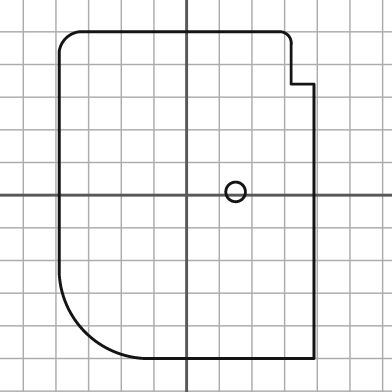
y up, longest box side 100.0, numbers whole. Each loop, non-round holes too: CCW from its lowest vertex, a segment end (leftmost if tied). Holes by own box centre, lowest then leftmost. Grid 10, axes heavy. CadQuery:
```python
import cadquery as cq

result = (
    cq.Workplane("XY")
    .moveTo(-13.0, -50.0)
    .lineTo(39.0, -50.0)
    .lineTo(39.0, 34.0)
    .lineTo(32.0, 34.0)
    .lineTo(32.0, 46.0)
    .threePointArc((31.0, 49.0), (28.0, 50.0))
    .lineTo(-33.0, 50.0)
    .threePointArc((-37.0, 48.0), (-39.0, 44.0))
    .lineTo(-39.0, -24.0)
    .threePointArc((-31.0, -42.0), (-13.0, -50.0))
    .close()
    .moveTo(15.0, 1.0)
    .circle(3.0)
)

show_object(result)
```